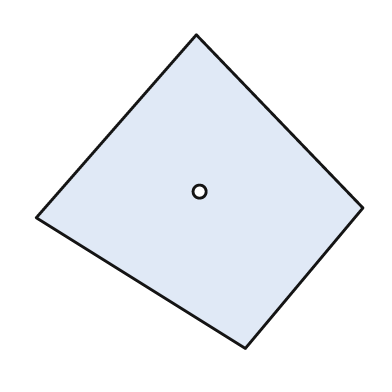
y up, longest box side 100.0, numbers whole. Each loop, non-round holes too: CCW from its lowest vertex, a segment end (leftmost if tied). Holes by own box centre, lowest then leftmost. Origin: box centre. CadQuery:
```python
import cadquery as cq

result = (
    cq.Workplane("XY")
    .moveTo(14.0, -48.0)
    .lineTo(50.0, -5.0)
    .lineTo(-1.0, 48.0)
    .lineTo(-50.0, -8.0)
    .close()
    .moveTo(0.0, 0.0)
    .circle(2.0)
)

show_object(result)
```